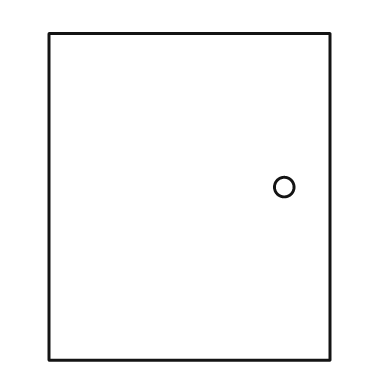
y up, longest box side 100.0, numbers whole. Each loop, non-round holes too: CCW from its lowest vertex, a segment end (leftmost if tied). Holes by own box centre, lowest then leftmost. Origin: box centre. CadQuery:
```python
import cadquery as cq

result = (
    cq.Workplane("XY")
    .moveTo(-43.0, -50.0)
    .lineTo(43.0, -50.0)
    .lineTo(43.0, 50.0)
    .lineTo(-43.0, 50.0)
    .close()
    .moveTo(29.0, 3.0)
    .circle(3.0)
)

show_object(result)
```